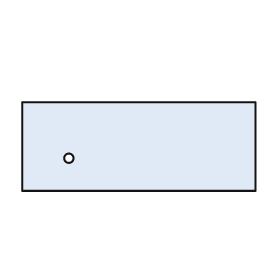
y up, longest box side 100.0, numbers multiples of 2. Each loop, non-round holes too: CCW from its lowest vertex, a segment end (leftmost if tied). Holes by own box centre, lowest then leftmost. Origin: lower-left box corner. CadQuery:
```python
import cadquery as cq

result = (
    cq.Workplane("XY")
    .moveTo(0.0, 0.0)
    .lineTo(100.0, 0.0)
    .lineTo(100.0, 38.0)
    .lineTo(0.0, 38.0)
    .close()
    .moveTo(20.0, 14.0)
    .circle(2.0)
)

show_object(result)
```